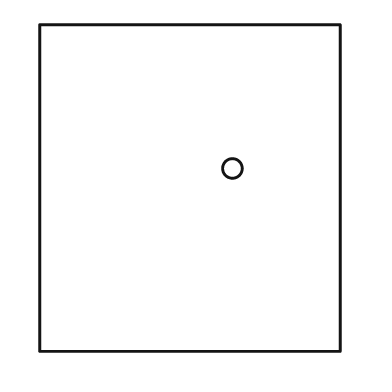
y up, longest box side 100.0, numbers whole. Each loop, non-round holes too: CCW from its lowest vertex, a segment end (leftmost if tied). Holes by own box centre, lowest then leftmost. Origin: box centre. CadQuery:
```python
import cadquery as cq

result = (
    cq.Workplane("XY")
    .moveTo(-46.0, -50.0)
    .lineTo(46.0, -50.0)
    .lineTo(46.0, 50.0)
    .lineTo(-46.0, 50.0)
    .close()
    .moveTo(13.0, 6.0)
    .circle(3.0)
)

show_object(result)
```